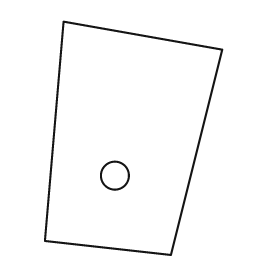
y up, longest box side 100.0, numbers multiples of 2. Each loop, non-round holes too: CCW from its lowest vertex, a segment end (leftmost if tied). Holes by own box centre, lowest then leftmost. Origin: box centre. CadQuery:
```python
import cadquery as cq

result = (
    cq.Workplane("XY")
    .moveTo(16.0, -50.0)
    .lineTo(38.0, 38.0)
    .lineTo(-30.0, 50.0)
    .lineTo(-38.0, -44.0)
    .close()
    .moveTo(-8.0, -16.0)
    .circle(6.0)
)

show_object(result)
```